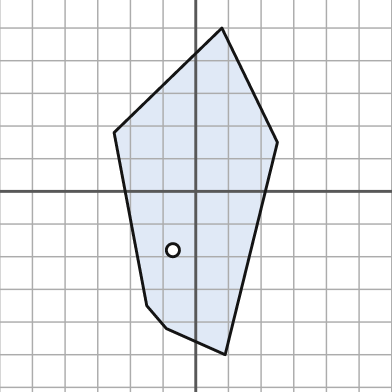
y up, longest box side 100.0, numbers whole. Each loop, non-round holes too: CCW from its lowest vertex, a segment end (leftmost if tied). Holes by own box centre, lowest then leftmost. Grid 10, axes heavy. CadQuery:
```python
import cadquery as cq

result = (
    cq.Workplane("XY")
    .moveTo(9.0, -50.0)
    .lineTo(25.0, 15.0)
    .lineTo(8.0, 50.0)
    .lineTo(-25.0, 18.0)
    .lineTo(-15.0, -35.0)
    .lineTo(-9.0, -42.0)
    .close()
    .moveTo(-7.0, -18.0)
    .circle(2.0)
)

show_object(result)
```